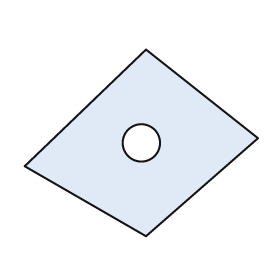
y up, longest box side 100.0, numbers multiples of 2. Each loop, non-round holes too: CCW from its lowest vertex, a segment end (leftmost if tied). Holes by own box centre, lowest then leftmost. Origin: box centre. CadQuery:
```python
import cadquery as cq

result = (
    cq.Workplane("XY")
    .moveTo(2.0, -40.0)
    .lineTo(50.0, 2.0)
    .lineTo(2.0, 40.0)
    .lineTo(-50.0, -10.0)
    .close()
    .moveTo(0.0, 0.0)
    .circle(8.0)
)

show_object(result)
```